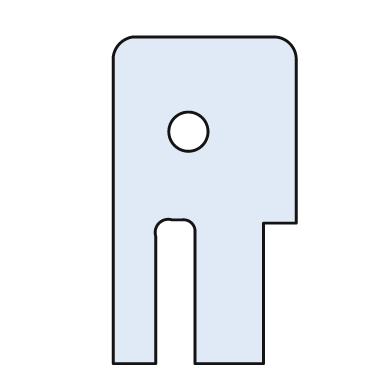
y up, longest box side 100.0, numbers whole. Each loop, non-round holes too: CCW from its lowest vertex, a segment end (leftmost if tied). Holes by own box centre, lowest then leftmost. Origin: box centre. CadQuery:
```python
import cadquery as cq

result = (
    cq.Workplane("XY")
    .moveTo(-28.0, -50.0)
    .lineTo(-15.0, -50.0)
    .lineTo(-15.0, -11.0)
    .threePointArc((-14.0, -7.0), (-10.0, -6.0))
    .lineTo(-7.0, -6.0)
    .threePointArc((-4.0, -7.0), (-3.0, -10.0))
    .lineTo(-3.0, -50.0)
    .lineTo(18.0, -50.0)
    .lineTo(18.0, -7.0)
    .lineTo(28.0, -7.0)
    .lineTo(28.0, 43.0)
    .threePointArc((26.0, 48.0), (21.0, 50.0))
    .lineTo(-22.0, 50.0)
    .threePointArc((-26.0, 48.0), (-28.0, 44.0))
    .close()
    .moveTo(-5.0, 21.0)
    .circle(6.0)
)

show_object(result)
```